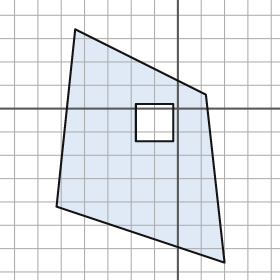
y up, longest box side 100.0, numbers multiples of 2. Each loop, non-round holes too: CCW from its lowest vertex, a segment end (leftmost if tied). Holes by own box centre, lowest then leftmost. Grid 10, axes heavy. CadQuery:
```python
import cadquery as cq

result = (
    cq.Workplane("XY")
    .moveTo(20.0, -66.0)
    .lineTo(12.0, 6.0)
    .lineTo(-44.0, 34.0)
    .lineTo(-52.0, -42.0)
    .close()
    .moveTo(-18.0, -14.0)
    .lineTo(-2.0, -14.0)
    .lineTo(-2.0, 2.0)
    .lineTo(-18.0, 2.0)
    .close()
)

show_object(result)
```